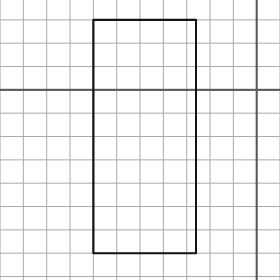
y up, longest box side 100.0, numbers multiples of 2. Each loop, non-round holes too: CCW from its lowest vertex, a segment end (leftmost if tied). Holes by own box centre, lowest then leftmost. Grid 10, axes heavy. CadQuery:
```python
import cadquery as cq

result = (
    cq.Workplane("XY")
    .moveTo(-70.0, -70.0)
    .lineTo(-26.0, -70.0)
    .lineTo(-26.0, 30.0)
    .lineTo(-70.0, 30.0)
    .close()
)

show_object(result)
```